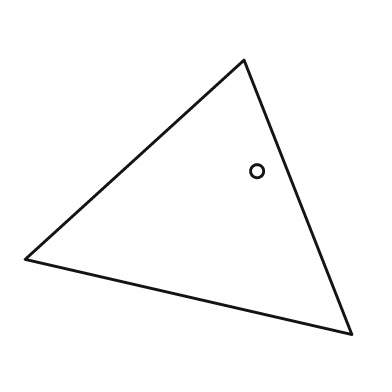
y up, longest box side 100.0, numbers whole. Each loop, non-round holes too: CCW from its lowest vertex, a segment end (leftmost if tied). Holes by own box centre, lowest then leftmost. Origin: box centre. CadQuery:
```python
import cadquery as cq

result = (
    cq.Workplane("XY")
    .moveTo(50.0, -42.0)
    .lineTo(17.0, 42.0)
    .lineTo(-50.0, -19.0)
    .close()
    .moveTo(21.0, 8.0)
    .circle(2.0)
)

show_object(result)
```